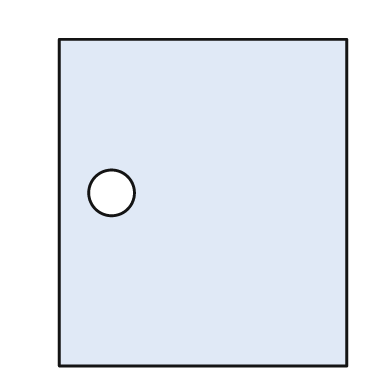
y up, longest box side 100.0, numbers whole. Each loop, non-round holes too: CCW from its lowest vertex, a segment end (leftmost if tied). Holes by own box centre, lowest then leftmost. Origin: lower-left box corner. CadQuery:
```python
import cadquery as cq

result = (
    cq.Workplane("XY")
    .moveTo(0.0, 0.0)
    .lineTo(88.0, 0.0)
    .lineTo(88.0, 100.0)
    .lineTo(0.0, 100.0)
    .close()
    .moveTo(16.0, 53.0)
    .circle(7.0)
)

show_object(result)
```